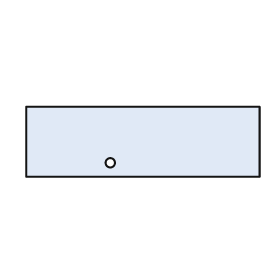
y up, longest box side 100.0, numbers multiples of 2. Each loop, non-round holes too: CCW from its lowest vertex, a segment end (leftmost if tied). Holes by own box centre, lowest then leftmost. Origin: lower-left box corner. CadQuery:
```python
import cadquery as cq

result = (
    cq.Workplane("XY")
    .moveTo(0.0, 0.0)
    .lineTo(100.0, 0.0)
    .lineTo(100.0, 30.0)
    .lineTo(0.0, 30.0)
    .close()
    .moveTo(36.0, 6.0)
    .circle(2.0)
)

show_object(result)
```